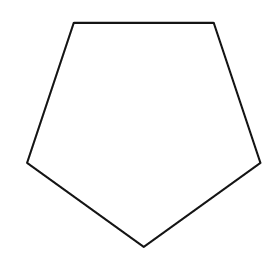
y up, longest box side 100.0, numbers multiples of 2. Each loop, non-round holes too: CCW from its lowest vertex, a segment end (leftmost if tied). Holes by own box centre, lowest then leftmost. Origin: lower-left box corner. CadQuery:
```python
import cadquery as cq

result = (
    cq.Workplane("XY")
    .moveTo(50.0, 0.0)
    .lineTo(100.0, 36.0)
    .lineTo(80.0, 96.0)
    .lineTo(20.0, 96.0)
    .lineTo(0.0, 36.0)
    .close()
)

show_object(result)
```